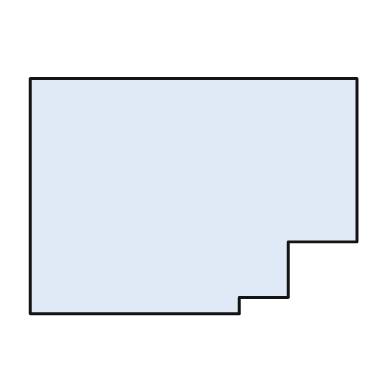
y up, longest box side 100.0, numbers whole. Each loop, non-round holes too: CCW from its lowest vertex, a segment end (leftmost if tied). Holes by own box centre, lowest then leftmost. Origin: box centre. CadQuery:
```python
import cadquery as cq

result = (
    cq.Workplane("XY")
    .moveTo(-50.0, -36.0)
    .lineTo(14.0, -36.0)
    .lineTo(14.0, -31.0)
    .lineTo(29.0, -31.0)
    .lineTo(29.0, -14.0)
    .lineTo(50.0, -14.0)
    .lineTo(50.0, 36.0)
    .lineTo(-50.0, 36.0)
    .close()
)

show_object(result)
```